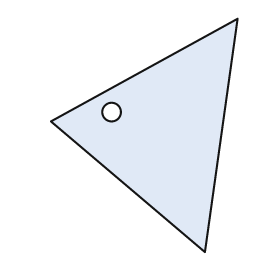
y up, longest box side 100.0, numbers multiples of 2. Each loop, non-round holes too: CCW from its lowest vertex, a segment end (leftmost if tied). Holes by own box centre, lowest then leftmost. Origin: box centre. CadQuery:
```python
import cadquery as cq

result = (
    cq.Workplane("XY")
    .moveTo(26.0, -50.0)
    .lineTo(40.0, 50.0)
    .lineTo(-40.0, 6.0)
    .close()
    .moveTo(-14.0, 10.0)
    .circle(4.0)
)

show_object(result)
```